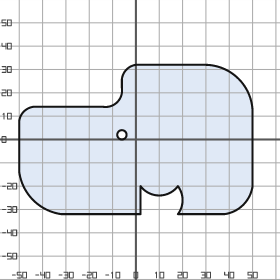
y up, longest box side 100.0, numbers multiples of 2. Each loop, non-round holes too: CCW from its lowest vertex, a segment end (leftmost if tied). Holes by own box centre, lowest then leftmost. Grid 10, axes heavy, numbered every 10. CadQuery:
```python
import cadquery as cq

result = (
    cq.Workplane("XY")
    .moveTo(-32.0, -32.0)
    .lineTo(2.0, -32.0)
    .lineTo(2.0, -20.0)
    .threePointArc((10.0, -24.0), (18.0, -20.0))
    .threePointArc((20.0, -26.0), (18.0, -32.0))
    .lineTo(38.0, -32.0)
    .threePointArc((46.0, -28.0), (50.0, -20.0))
    .lineTo(50.0, 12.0)
    .threePointArc((44.0, 26.0), (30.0, 32.0))
    .lineTo(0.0, 32.0)
    .threePointArc((-4.0, 30.0), (-6.0, 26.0))
    .lineTo(-6.0, 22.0)
    .threePointArc((-8.0, 16.0), (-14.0, 14.0))
    .lineTo(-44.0, 14.0)
    .threePointArc((-48.0, 12.0), (-50.0, 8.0))
    .lineTo(-50.0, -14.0)
    .threePointArc((-44.0, -26.0), (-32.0, -32.0))
    .close()
    .moveTo(-6.0, 2.0)
    .circle(2.0)
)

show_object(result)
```